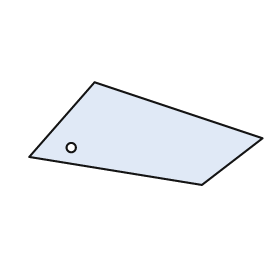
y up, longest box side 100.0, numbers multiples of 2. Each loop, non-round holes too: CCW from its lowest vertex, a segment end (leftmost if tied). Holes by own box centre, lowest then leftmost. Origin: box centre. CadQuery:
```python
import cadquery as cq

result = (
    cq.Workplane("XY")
    .moveTo(24.0, -22.0)
    .lineTo(50.0, -2.0)
    .lineTo(-22.0, 22.0)
    .lineTo(-50.0, -10.0)
    .close()
    .moveTo(-32.0, -6.0)
    .circle(2.0)
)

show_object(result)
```